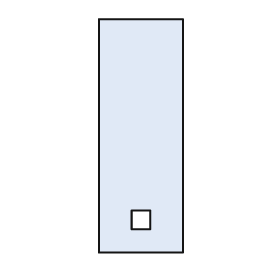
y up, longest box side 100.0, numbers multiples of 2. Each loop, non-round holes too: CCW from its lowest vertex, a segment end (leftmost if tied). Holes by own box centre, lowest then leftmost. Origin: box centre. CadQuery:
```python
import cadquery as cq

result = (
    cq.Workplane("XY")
    .moveTo(-18.0, -50.0)
    .lineTo(18.0, -50.0)
    .lineTo(18.0, 50.0)
    .lineTo(-18.0, 50.0)
    .close()
    .moveTo(-4.0, -40.0)
    .lineTo(4.0, -40.0)
    .lineTo(4.0, -32.0)
    .lineTo(-4.0, -32.0)
    .close()
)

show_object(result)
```